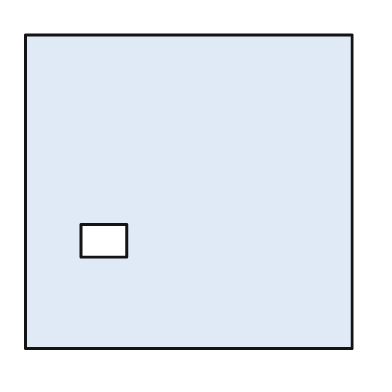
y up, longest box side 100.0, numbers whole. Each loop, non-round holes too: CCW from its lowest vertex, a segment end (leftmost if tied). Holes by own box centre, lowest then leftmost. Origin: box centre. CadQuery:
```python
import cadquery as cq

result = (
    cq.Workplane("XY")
    .moveTo(-50.0, -48.0)
    .lineTo(50.0, -48.0)
    .lineTo(50.0, 48.0)
    .lineTo(-50.0, 48.0)
    .close()
    .moveTo(-33.0, -20.0)
    .lineTo(-19.0, -20.0)
    .lineTo(-19.0, -10.0)
    .lineTo(-33.0, -10.0)
    .close()
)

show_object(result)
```